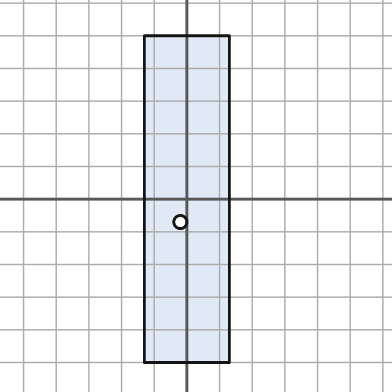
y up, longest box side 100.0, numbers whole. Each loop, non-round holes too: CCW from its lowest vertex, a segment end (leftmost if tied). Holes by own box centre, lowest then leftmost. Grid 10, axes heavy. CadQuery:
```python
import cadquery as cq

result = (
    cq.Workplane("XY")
    .moveTo(-13.0, -50.0)
    .lineTo(13.0, -50.0)
    .lineTo(13.0, 50.0)
    .lineTo(-13.0, 50.0)
    .close()
    .moveTo(-2.0, -7.0)
    .circle(2.0)
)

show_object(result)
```